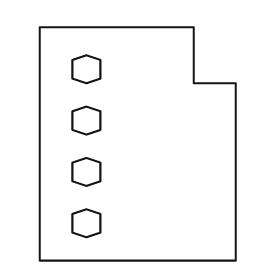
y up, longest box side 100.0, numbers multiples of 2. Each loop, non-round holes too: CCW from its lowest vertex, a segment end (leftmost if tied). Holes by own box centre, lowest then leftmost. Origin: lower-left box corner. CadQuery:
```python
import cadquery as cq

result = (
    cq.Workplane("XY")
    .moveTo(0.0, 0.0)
    .lineTo(84.0, 0.0)
    .lineTo(84.0, 76.0)
    .lineTo(66.0, 76.0)
    .lineTo(66.0, 100.0)
    .lineTo(0.0, 100.0)
    .close()
    .moveTo(20.0, 10.0)
    .lineTo(26.0, 12.0)
    .lineTo(26.0, 20.0)
    .lineTo(20.0, 22.0)
    .lineTo(14.0, 20.0)
    .lineTo(14.0, 12.0)
    .close()
    .moveTo(20.0, 32.0)
    .lineTo(26.0, 34.0)
    .lineTo(26.0, 42.0)
    .lineTo(20.0, 44.0)
    .lineTo(14.0, 42.0)
    .lineTo(14.0, 34.0)
    .close()
    .moveTo(20.0, 54.0)
    .lineTo(26.0, 56.0)
    .lineTo(26.0, 64.0)
    .lineTo(20.0, 66.0)
    .lineTo(14.0, 64.0)
    .lineTo(14.0, 56.0)
    .close()
    .moveTo(20.0, 76.0)
    .lineTo(26.0, 78.0)
    .lineTo(26.0, 86.0)
    .lineTo(20.0, 88.0)
    .lineTo(14.0, 86.0)
    .lineTo(14.0, 78.0)
    .close()
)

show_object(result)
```